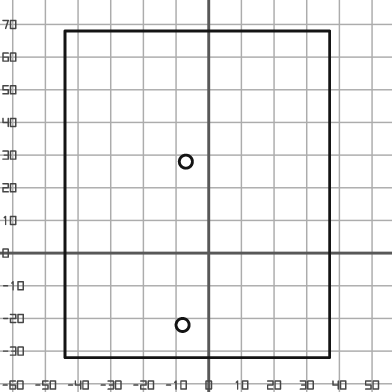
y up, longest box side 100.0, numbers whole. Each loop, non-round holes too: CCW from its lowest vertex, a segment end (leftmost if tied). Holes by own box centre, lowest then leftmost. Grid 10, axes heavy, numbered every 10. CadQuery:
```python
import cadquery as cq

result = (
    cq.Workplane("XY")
    .moveTo(-44.0, -32.0)
    .lineTo(37.0, -32.0)
    .lineTo(37.0, 68.0)
    .lineTo(-44.0, 68.0)
    .close()
    .moveTo(-8.0, -22.0)
    .circle(2.0)
    .moveTo(-7.0, 28.0)
    .circle(2.0)
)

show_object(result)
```